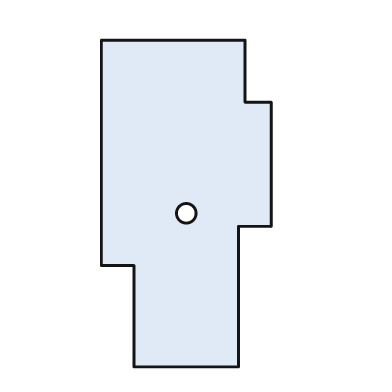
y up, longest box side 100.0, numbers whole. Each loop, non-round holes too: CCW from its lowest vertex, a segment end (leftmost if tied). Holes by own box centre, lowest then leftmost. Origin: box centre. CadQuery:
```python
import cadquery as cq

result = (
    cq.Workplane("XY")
    .moveTo(-16.0, -50.0)
    .lineTo(16.0, -50.0)
    .lineTo(16.0, -7.0)
    .lineTo(26.0, -7.0)
    .lineTo(26.0, 31.0)
    .lineTo(18.0, 31.0)
    .lineTo(18.0, 50.0)
    .lineTo(-26.0, 50.0)
    .lineTo(-26.0, -19.0)
    .lineTo(-16.0, -19.0)
    .close()
    .moveTo(0.0, -3.0)
    .circle(3.0)
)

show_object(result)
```